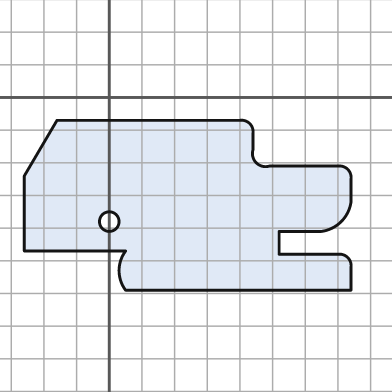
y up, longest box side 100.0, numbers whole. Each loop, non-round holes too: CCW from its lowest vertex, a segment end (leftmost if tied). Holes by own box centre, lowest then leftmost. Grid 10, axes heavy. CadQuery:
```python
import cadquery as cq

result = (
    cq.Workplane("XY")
    .moveTo(5.0, -59.0)
    .lineTo(74.0, -59.0)
    .lineTo(74.0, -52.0)
    .threePointArc((73.0, -49.0), (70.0, -48.0))
    .lineTo(52.0, -48.0)
    .lineTo(52.0, -41.0)
    .lineTo(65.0, -41.0)
    .threePointArc((71.0, -38.0), (74.0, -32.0))
    .lineTo(74.0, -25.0)
    .threePointArc((73.0, -22.0), (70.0, -21.0))
    .lineTo(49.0, -21.0)
    .threePointArc((45.0, -20.0), (44.0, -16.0))
    .lineTo(44.0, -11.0)
    .threePointArc((43.0, -8.0), (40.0, -7.0))
    .lineTo(-16.0, -7.0)
    .lineTo(-26.0, -24.0)
    .lineTo(-26.0, -47.0)
    .lineTo(5.0, -47.0)
    .threePointArc((3.0, -53.0), (5.0, -59.0))
    .close()
    .moveTo(0.0, -38.0)
    .circle(3.0)
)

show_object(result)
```